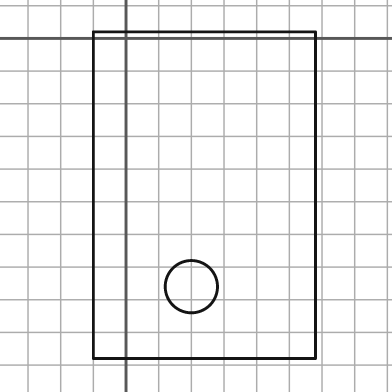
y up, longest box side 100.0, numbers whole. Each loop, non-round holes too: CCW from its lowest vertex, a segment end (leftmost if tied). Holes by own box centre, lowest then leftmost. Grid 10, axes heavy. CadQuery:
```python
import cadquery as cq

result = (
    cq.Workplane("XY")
    .moveTo(-10.0, -98.0)
    .lineTo(58.0, -98.0)
    .lineTo(58.0, 2.0)
    .lineTo(-10.0, 2.0)
    .close()
    .moveTo(20.0, -76.0)
    .circle(8.0)
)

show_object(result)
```